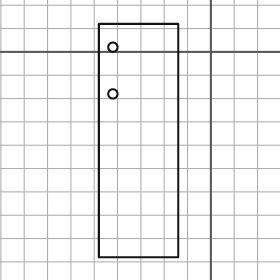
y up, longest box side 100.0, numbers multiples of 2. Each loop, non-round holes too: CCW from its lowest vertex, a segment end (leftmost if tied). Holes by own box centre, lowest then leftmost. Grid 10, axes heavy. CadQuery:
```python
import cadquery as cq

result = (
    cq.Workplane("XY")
    .moveTo(-48.0, -88.0)
    .lineTo(-14.0, -88.0)
    .lineTo(-14.0, 12.0)
    .lineTo(-48.0, 12.0)
    .close()
    .moveTo(-42.0, -18.0)
    .circle(2.0)
    .moveTo(-42.0, 2.0)
    .circle(2.0)
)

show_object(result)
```